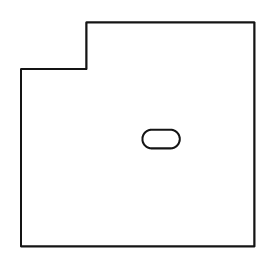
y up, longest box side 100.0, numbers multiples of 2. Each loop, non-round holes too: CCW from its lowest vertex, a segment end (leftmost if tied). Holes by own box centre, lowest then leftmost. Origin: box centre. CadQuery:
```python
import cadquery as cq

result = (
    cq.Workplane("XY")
    .moveTo(-50.0, -48.0)
    .lineTo(50.0, -48.0)
    .lineTo(50.0, 48.0)
    .lineTo(-22.0, 48.0)
    .lineTo(-22.0, 28.0)
    .lineTo(-50.0, 28.0)
    .close()
    .moveTo(6.0, -6.0)
    .lineTo(14.0, -6.0)
    .threePointArc((18.0, -2.0), (14.0, 2.0))
    .lineTo(6.0, 2.0)
    .threePointArc((2.0, -2.0), (6.0, -6.0))
    .close()
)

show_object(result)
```